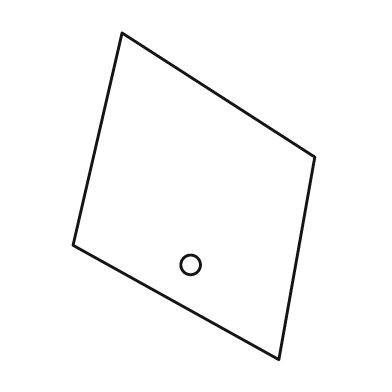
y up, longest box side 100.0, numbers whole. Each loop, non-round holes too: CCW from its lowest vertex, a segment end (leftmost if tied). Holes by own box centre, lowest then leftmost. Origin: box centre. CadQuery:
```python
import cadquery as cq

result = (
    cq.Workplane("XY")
    .moveTo(26.0, -50.0)
    .lineTo(37.0, 12.0)
    .lineTo(-22.0, 50.0)
    .lineTo(-37.0, -15.0)
    .close()
    .moveTo(-1.0, -21.0)
    .circle(3.0)
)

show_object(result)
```